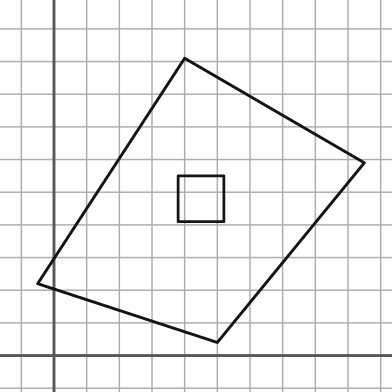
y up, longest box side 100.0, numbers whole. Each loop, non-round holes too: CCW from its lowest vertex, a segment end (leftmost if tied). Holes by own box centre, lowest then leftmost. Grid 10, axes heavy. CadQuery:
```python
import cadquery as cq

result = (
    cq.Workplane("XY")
    .moveTo(50.0, 4.0)
    .lineTo(95.0, 59.0)
    .lineTo(40.0, 91.0)
    .lineTo(-5.0, 22.0)
    .close()
    .moveTo(38.0, 41.0)
    .lineTo(52.0, 41.0)
    .lineTo(52.0, 55.0)
    .lineTo(38.0, 55.0)
    .close()
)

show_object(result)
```